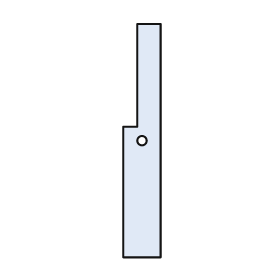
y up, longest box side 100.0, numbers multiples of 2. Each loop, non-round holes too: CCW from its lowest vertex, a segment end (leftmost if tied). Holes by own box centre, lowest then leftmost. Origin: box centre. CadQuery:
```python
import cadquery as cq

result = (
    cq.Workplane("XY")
    .moveTo(-8.0, -50.0)
    .lineTo(8.0, -50.0)
    .lineTo(8.0, 50.0)
    .lineTo(-2.0, 50.0)
    .lineTo(-2.0, 6.0)
    .lineTo(-8.0, 6.0)
    .close()
    .moveTo(0.0, 0.0)
    .circle(2.0)
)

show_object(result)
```